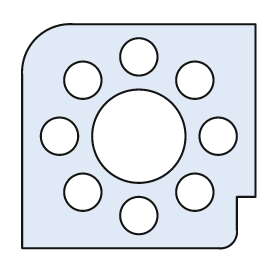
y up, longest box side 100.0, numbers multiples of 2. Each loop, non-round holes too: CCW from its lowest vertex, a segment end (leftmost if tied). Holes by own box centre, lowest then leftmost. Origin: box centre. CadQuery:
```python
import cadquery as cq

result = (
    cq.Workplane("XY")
    .moveTo(-50.0, -48.0)
    .lineTo(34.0, -48.0)
    .threePointArc((40.0, -46.0), (42.0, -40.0))
    .lineTo(42.0, -26.0)
    .lineTo(50.0, -26.0)
    .lineTo(50.0, 48.0)
    .lineTo(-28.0, 48.0)
    .threePointArc((-44.0, 42.0), (-50.0, 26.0))
    .close()
    .moveTo(0.0, -34.0)
    .circle(8.0)
    .moveTo(-24.0, -24.0)
    .circle(8.0)
    .moveTo(24.0, -24.0)
    .circle(8.0)
    .moveTo(-34.0, 0.0)
    .circle(8.0)
    .moveTo(0.0, 0.0)
    .circle(20.0)
    .moveTo(34.0, 0.0)
    .circle(8.0)
    .moveTo(-24.0, 24.0)
    .circle(8.0)
    .moveTo(24.0, 24.0)
    .circle(8.0)
    .moveTo(0.0, 34.0)
    .circle(8.0)
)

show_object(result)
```